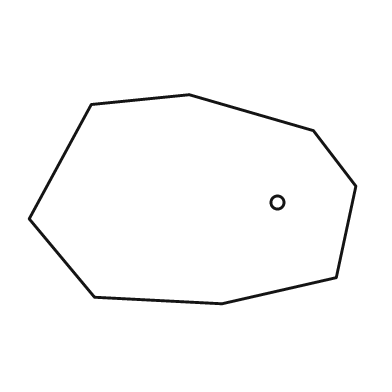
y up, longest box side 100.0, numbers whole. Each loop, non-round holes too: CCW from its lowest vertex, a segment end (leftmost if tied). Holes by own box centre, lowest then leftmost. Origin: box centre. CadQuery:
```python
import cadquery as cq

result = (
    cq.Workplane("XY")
    .moveTo(9.0, -32.0)
    .lineTo(44.0, -24.0)
    .lineTo(50.0, 4.0)
    .lineTo(37.0, 21.0)
    .lineTo(-1.0, 32.0)
    .lineTo(-31.0, 29.0)
    .lineTo(-50.0, -6.0)
    .lineTo(-30.0, -30.0)
    .close()
    .moveTo(26.0, -1.0)
    .circle(2.0)
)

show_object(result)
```